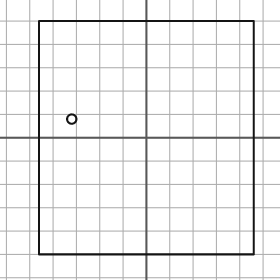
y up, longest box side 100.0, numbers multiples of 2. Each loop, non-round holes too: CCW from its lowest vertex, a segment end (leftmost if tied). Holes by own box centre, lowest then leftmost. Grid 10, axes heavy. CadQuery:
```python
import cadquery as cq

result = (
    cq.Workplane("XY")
    .moveTo(-46.0, -50.0)
    .lineTo(46.0, -50.0)
    .lineTo(46.0, 50.0)
    .lineTo(-46.0, 50.0)
    .close()
    .moveTo(-32.0, 8.0)
    .circle(2.0)
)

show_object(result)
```